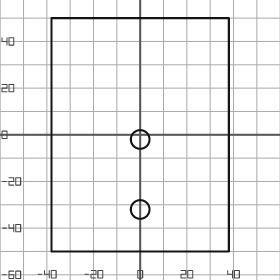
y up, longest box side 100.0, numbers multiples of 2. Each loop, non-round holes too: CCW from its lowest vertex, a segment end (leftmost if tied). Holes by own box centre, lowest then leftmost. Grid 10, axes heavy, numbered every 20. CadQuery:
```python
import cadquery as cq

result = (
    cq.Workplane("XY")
    .moveTo(-38.0, -50.0)
    .lineTo(38.0, -50.0)
    .lineTo(38.0, 50.0)
    .lineTo(-38.0, 50.0)
    .close()
    .moveTo(0.0, -32.0)
    .circle(4.0)
    .moveTo(0.0, -2.0)
    .circle(4.0)
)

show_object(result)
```